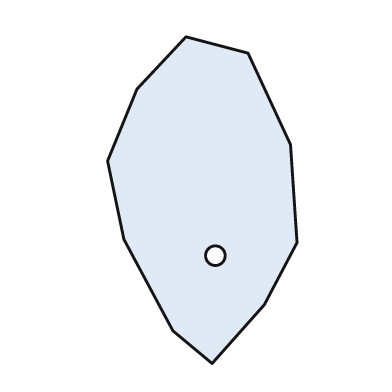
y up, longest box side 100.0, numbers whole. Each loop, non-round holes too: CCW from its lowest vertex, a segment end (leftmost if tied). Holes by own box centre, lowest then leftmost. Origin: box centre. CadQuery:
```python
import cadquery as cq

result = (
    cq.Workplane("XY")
    .moveTo(3.0, -50.0)
    .lineTo(19.0, -32.0)
    .lineTo(29.0, -13.0)
    .lineTo(27.0, 17.0)
    .lineTo(14.0, 45.0)
    .lineTo(-5.0, 50.0)
    .lineTo(-20.0, 34.0)
    .lineTo(-29.0, 12.0)
    .lineTo(-24.0, -12.0)
    .lineTo(-9.0, -40.0)
    .close()
    .moveTo(4.0, -17.0)
    .circle(3.0)
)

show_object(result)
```